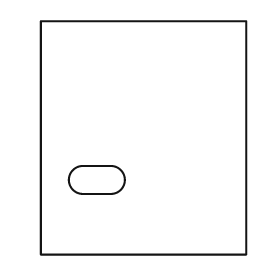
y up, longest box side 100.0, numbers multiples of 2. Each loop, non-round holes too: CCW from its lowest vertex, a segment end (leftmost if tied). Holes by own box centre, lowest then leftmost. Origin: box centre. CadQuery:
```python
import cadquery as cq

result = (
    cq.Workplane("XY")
    .moveTo(-44.0, -50.0)
    .lineTo(44.0, -50.0)
    .lineTo(44.0, 50.0)
    .lineTo(-44.0, 50.0)
    .close()
    .moveTo(-26.0, -24.0)
    .lineTo(-14.0, -24.0)
    .threePointArc((-8.0, -18.0), (-14.0, -12.0))
    .lineTo(-26.0, -12.0)
    .threePointArc((-32.0, -18.0), (-26.0, -24.0))
    .close()
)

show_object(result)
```